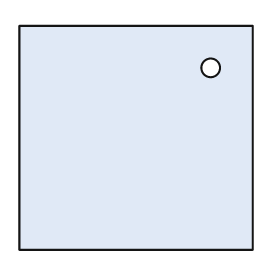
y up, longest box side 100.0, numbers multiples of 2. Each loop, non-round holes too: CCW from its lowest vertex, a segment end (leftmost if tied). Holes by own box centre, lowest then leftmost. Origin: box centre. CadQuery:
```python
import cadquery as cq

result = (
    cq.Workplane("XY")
    .moveTo(-50.0, -48.0)
    .lineTo(50.0, -48.0)
    .lineTo(50.0, 48.0)
    .lineTo(-50.0, 48.0)
    .close()
    .moveTo(32.0, 30.0)
    .circle(4.0)
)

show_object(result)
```